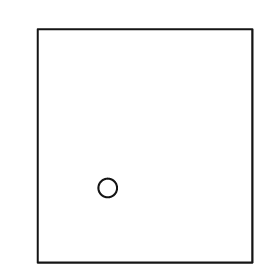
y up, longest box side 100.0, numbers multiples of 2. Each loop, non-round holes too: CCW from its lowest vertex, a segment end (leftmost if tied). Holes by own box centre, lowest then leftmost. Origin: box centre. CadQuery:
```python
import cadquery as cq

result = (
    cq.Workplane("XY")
    .moveTo(-46.0, -50.0)
    .lineTo(46.0, -50.0)
    .lineTo(46.0, 50.0)
    .lineTo(-46.0, 50.0)
    .close()
    .moveTo(-16.0, -18.0)
    .circle(4.0)
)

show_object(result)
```